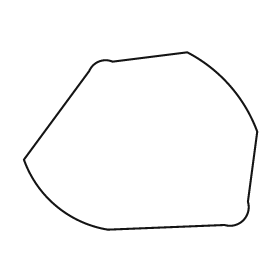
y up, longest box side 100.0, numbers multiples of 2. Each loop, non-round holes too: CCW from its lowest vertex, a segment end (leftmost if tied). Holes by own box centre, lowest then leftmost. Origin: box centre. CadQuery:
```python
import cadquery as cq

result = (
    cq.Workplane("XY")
    .moveTo(-14.0, -38.0)
    .lineTo(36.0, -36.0)
    .threePointArc((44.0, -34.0), (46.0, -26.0))
    .lineTo(50.0, 4.0)
    .threePointArc((38.0, 24.0), (20.0, 38.0))
    .lineTo(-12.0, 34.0)
    .threePointArc((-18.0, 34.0), (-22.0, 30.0))
    .lineTo(-50.0, -8.0)
    .threePointArc((-36.0, -28.0), (-14.0, -38.0))
    .close()
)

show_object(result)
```